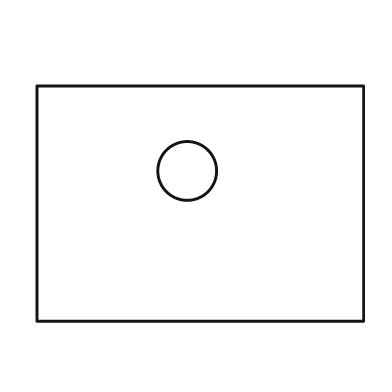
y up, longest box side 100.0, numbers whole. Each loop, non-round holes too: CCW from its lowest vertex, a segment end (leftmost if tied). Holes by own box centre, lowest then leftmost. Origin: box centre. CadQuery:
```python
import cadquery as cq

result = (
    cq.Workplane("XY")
    .moveTo(-50.0, -36.0)
    .lineTo(50.0, -36.0)
    .lineTo(50.0, 36.0)
    .lineTo(-50.0, 36.0)
    .close()
    .moveTo(-4.0, 10.0)
    .circle(9.0)
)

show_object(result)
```